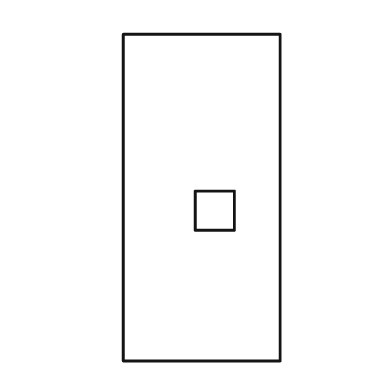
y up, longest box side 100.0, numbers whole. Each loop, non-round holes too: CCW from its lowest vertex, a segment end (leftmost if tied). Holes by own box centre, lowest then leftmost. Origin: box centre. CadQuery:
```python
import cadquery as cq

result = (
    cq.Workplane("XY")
    .moveTo(-24.0, -50.0)
    .lineTo(24.0, -50.0)
    .lineTo(24.0, 50.0)
    .lineTo(-24.0, 50.0)
    .close()
    .moveTo(-2.0, -10.0)
    .lineTo(10.0, -10.0)
    .lineTo(10.0, 2.0)
    .lineTo(-2.0, 2.0)
    .close()
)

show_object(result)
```